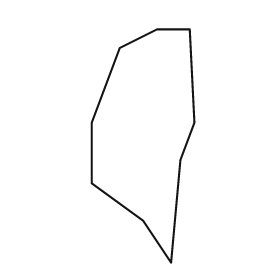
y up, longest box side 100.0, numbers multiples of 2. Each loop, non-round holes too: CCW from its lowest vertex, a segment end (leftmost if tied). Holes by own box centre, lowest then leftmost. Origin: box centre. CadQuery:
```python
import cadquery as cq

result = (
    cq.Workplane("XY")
    .moveTo(12.0, -50.0)
    .lineTo(16.0, -6.0)
    .lineTo(22.0, 10.0)
    .lineTo(20.0, 50.0)
    .lineTo(6.0, 50.0)
    .lineTo(-10.0, 42.0)
    .lineTo(-22.0, 10.0)
    .lineTo(-22.0, -16.0)
    .lineTo(0.0, -32.0)
    .close()
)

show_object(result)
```